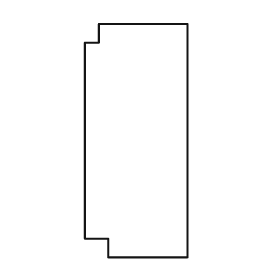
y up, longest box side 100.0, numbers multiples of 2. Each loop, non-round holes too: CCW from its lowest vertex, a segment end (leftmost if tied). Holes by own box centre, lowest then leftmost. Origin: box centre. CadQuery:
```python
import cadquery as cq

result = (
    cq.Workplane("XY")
    .moveTo(-12.0, -50.0)
    .lineTo(22.0, -50.0)
    .lineTo(22.0, 50.0)
    .lineTo(-16.0, 50.0)
    .lineTo(-16.0, 42.0)
    .lineTo(-22.0, 42.0)
    .lineTo(-22.0, -42.0)
    .lineTo(-12.0, -42.0)
    .close()
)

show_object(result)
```